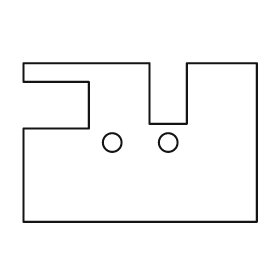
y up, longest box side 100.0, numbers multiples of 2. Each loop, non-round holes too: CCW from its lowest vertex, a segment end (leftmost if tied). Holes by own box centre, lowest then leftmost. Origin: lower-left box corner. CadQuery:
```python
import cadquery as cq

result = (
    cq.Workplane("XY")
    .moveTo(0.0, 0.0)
    .lineTo(100.0, 0.0)
    .lineTo(100.0, 68.0)
    .lineTo(70.0, 68.0)
    .lineTo(70.0, 42.0)
    .lineTo(54.0, 42.0)
    .lineTo(54.0, 68.0)
    .lineTo(0.0, 68.0)
    .lineTo(0.0, 60.0)
    .lineTo(28.0, 60.0)
    .lineTo(28.0, 40.0)
    .lineTo(0.0, 40.0)
    .close()
    .moveTo(38.0, 34.0)
    .circle(4.0)
    .moveTo(62.0, 34.0)
    .circle(4.0)
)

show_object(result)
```